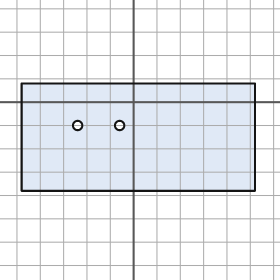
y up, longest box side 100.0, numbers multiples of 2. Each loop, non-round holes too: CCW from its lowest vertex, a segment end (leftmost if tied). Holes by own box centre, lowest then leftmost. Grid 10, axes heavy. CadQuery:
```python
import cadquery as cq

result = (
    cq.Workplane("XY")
    .moveTo(-48.0, -38.0)
    .lineTo(52.0, -38.0)
    .lineTo(52.0, 8.0)
    .lineTo(-48.0, 8.0)
    .close()
    .moveTo(-24.0, -10.0)
    .circle(2.0)
    .moveTo(-6.0, -10.0)
    .circle(2.0)
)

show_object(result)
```